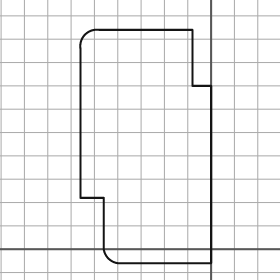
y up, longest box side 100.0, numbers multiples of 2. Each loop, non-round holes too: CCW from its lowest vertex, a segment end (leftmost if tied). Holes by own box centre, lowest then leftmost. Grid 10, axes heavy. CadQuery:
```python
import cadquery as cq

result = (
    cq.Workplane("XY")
    .moveTo(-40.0, -6.0)
    .lineTo(0.0, -6.0)
    .lineTo(0.0, 70.0)
    .lineTo(-8.0, 70.0)
    .lineTo(-8.0, 94.0)
    .lineTo(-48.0, 94.0)
    .threePointArc((-54.0, 92.0), (-56.0, 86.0))
    .lineTo(-56.0, 22.0)
    .lineTo(-46.0, 22.0)
    .lineTo(-46.0, 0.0)
    .threePointArc((-44.0, -4.0), (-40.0, -6.0))
    .close()
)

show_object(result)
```